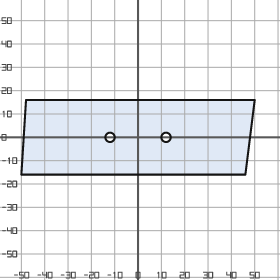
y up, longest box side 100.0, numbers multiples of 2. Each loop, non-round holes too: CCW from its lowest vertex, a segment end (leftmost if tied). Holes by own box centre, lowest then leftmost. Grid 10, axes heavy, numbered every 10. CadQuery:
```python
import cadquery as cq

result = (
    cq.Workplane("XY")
    .moveTo(-50.0, -16.0)
    .lineTo(46.0, -16.0)
    .lineTo(50.0, 16.0)
    .lineTo(-48.0, 16.0)
    .close()
    .moveTo(-12.0, 0.0)
    .circle(2.0)
    .moveTo(12.0, 0.0)
    .circle(2.0)
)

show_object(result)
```